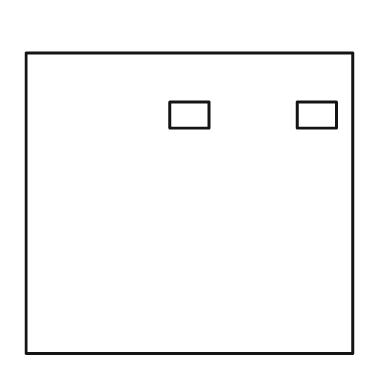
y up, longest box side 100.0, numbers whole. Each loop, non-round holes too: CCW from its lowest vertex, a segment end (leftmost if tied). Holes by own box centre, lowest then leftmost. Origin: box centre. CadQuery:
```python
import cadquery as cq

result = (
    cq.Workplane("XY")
    .moveTo(-50.0, -46.0)
    .lineTo(50.0, -46.0)
    .lineTo(50.0, 46.0)
    .lineTo(-50.0, 46.0)
    .close()
    .moveTo(-6.0, 23.0)
    .lineTo(6.0, 23.0)
    .lineTo(6.0, 31.0)
    .lineTo(-6.0, 31.0)
    .close()
    .moveTo(33.0, 23.0)
    .lineTo(45.0, 23.0)
    .lineTo(45.0, 31.0)
    .lineTo(33.0, 31.0)
    .close()
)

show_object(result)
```